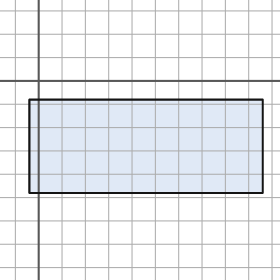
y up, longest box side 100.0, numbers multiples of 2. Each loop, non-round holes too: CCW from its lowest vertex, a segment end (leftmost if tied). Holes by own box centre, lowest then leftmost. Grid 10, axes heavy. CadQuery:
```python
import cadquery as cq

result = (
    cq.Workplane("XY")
    .moveTo(-4.0, -48.0)
    .lineTo(96.0, -48.0)
    .lineTo(96.0, -8.0)
    .lineTo(-4.0, -8.0)
    .close()
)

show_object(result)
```